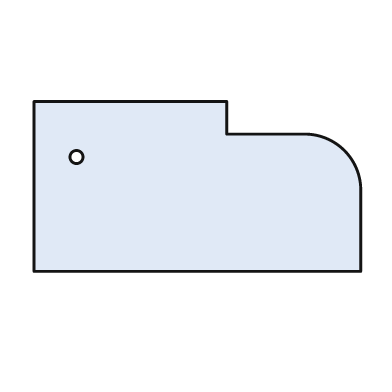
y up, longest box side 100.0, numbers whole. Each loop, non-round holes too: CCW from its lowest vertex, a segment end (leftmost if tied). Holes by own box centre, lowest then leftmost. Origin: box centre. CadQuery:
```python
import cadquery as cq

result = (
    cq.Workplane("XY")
    .moveTo(-50.0, -26.0)
    .lineTo(50.0, -26.0)
    .lineTo(50.0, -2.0)
    .threePointArc((45.0, 11.0), (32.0, 16.0))
    .lineTo(9.0, 16.0)
    .lineTo(9.0, 26.0)
    .lineTo(-50.0, 26.0)
    .close()
    .moveTo(-37.0, 9.0)
    .circle(2.0)
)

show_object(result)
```